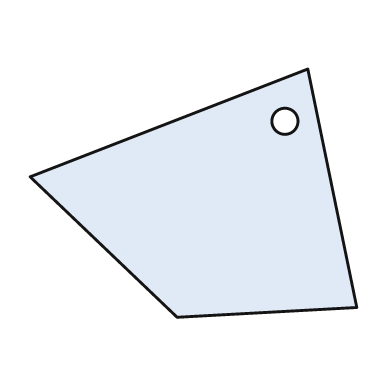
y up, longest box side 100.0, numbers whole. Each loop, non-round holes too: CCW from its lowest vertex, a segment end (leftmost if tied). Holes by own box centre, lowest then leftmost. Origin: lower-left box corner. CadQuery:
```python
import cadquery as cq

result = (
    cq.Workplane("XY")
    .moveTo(45.0, 0.0)
    .lineTo(100.0, 3.0)
    .lineTo(85.0, 76.0)
    .lineTo(0.0, 43.0)
    .close()
    .moveTo(78.0, 60.0)
    .circle(4.0)
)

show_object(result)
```